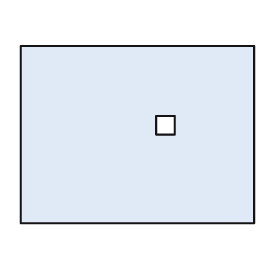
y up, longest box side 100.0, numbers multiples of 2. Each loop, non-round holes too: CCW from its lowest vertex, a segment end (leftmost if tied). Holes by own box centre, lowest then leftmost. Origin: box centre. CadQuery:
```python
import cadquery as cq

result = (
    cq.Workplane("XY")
    .moveTo(-50.0, -38.0)
    .lineTo(50.0, -38.0)
    .lineTo(50.0, 38.0)
    .lineTo(-50.0, 38.0)
    .close()
    .moveTo(8.0, 0.0)
    .lineTo(16.0, 0.0)
    .lineTo(16.0, 8.0)
    .lineTo(8.0, 8.0)
    .close()
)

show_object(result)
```